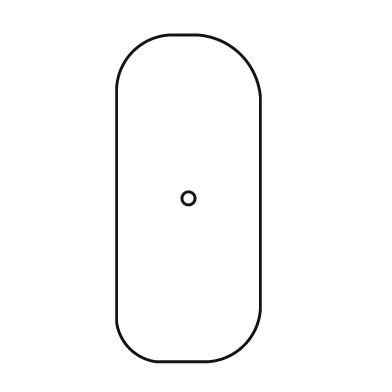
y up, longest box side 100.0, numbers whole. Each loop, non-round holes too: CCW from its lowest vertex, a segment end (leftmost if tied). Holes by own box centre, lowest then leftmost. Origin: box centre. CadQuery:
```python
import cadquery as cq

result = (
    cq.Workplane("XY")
    .moveTo(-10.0, -50.0)
    .lineTo(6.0, -50.0)
    .threePointArc((17.0, -45.0), (22.0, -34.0))
    .lineTo(22.0, 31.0)
    .threePointArc((16.0, 44.0), (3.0, 50.0))
    .lineTo(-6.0, 50.0)
    .threePointArc((-17.0, 45.0), (-22.0, 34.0))
    .lineTo(-22.0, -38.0)
    .threePointArc((-18.0, -46.0), (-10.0, -50.0))
    .close()
    .moveTo(0.0, 0.0)
    .circle(2.0)
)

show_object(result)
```